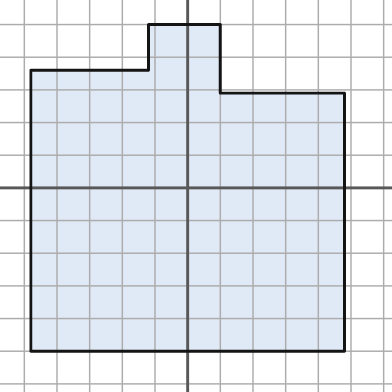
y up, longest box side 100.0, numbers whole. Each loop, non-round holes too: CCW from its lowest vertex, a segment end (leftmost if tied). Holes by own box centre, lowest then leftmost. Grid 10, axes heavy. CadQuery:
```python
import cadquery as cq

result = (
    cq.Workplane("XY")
    .moveTo(-48.0, -50.0)
    .lineTo(48.0, -50.0)
    .lineTo(48.0, 29.0)
    .lineTo(10.0, 29.0)
    .lineTo(10.0, 50.0)
    .lineTo(-12.0, 50.0)
    .lineTo(-12.0, 36.0)
    .lineTo(-48.0, 36.0)
    .close()
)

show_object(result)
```